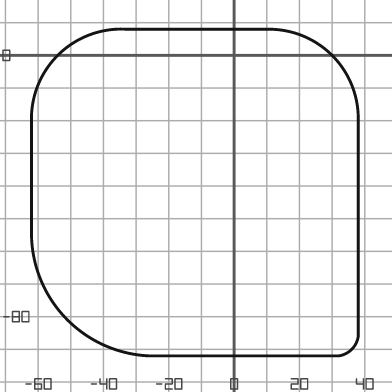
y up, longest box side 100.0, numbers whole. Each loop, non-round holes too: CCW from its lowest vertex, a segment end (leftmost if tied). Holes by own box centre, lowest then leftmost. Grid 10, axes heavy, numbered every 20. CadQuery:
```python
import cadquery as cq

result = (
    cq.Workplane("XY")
    .moveTo(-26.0, -92.0)
    .lineTo(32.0, -92.0)
    .threePointArc((36.0, -90.0), (38.0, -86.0))
    .lineTo(38.0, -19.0)
    .threePointArc((30.0, 0.0), (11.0, 8.0))
    .lineTo(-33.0, 8.0)
    .threePointArc((-54.0, 0.0), (-62.0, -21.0))
    .lineTo(-62.0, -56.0)
    .threePointArc((-51.0, -81.0), (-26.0, -92.0))
    .close()
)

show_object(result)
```